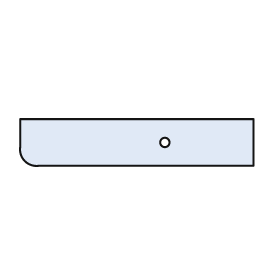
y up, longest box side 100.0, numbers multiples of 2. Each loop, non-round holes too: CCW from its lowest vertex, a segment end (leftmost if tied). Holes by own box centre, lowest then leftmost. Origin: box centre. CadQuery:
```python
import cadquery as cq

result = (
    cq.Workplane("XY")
    .moveTo(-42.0, -10.0)
    .lineTo(50.0, -10.0)
    .lineTo(50.0, 10.0)
    .lineTo(-50.0, 10.0)
    .lineTo(-50.0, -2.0)
    .threePointArc((-48.0, -8.0), (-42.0, -10.0))
    .close()
    .moveTo(12.0, 0.0)
    .circle(2.0)
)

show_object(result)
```